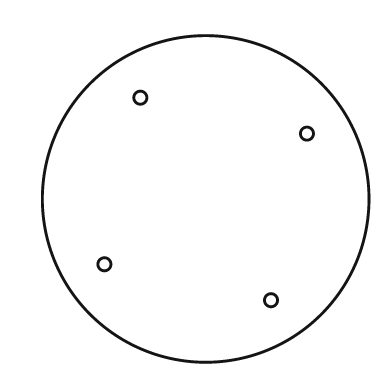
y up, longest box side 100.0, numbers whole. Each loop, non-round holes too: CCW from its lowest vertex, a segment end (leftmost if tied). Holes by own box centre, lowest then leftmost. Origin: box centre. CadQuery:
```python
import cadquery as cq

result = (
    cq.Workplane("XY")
    .moveTo(0.0, 0.0)
    .circle(50.0)
    .moveTo(20.0, -31.0)
    .circle(2.0)
    .moveTo(-31.0, -20.0)
    .circle(2.0)
    .moveTo(31.0, 20.0)
    .circle(2.0)
    .moveTo(-20.0, 31.0)
    .circle(2.0)
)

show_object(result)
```